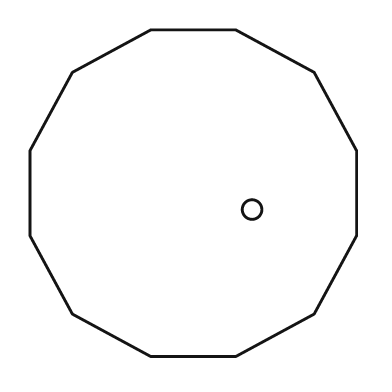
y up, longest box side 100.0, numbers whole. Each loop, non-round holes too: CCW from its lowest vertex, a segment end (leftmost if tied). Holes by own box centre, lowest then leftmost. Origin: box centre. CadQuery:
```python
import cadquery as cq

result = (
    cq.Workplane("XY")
    .moveTo(-13.0, -50.0)
    .lineTo(13.0, -50.0)
    .lineTo(37.0, -37.0)
    .lineTo(50.0, -13.0)
    .lineTo(50.0, 13.0)
    .lineTo(37.0, 37.0)
    .lineTo(13.0, 50.0)
    .lineTo(-13.0, 50.0)
    .lineTo(-37.0, 37.0)
    .lineTo(-50.0, 13.0)
    .lineTo(-50.0, -13.0)
    .lineTo(-37.0, -37.0)
    .close()
    .moveTo(18.0, -5.0)
    .circle(3.0)
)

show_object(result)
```